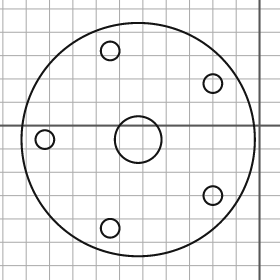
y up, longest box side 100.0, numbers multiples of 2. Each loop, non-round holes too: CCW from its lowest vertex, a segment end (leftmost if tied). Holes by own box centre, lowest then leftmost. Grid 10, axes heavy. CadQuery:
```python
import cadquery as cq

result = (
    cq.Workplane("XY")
    .moveTo(-52.0, -6.0)
    .circle(50.0)
    .moveTo(-64.0, -44.0)
    .circle(4.0)
    .moveTo(-20.0, -30.0)
    .circle(4.0)
    .moveTo(-92.0, -6.0)
    .circle(4.0)
    .moveTo(-52.0, -6.0)
    .circle(10.0)
    .moveTo(-20.0, 18.0)
    .circle(4.0)
    .moveTo(-64.0, 32.0)
    .circle(4.0)
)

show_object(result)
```